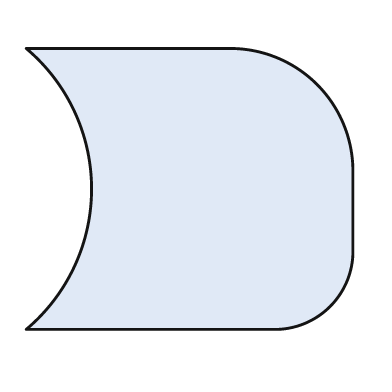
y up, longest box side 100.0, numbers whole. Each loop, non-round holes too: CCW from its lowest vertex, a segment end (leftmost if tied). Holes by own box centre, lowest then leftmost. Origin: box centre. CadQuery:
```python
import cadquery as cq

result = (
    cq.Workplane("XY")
    .moveTo(-50.0, -43.0)
    .lineTo(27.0, -43.0)
    .threePointArc((43.0, -36.0), (50.0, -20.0))
    .lineTo(50.0, 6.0)
    .threePointArc((39.0, 32.0), (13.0, 43.0))
    .lineTo(-50.0, 43.0)
    .threePointArc((-30.0, 0.0), (-50.0, -43.0))
    .close()
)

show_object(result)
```